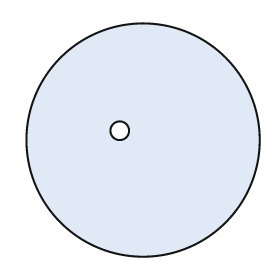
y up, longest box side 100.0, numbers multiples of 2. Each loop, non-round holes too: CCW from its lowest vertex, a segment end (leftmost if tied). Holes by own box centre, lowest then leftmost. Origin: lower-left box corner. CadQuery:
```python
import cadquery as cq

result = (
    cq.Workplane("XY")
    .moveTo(50.0, 50.0)
    .circle(50.0)
    .moveTo(40.0, 54.0)
    .circle(4.0)
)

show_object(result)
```